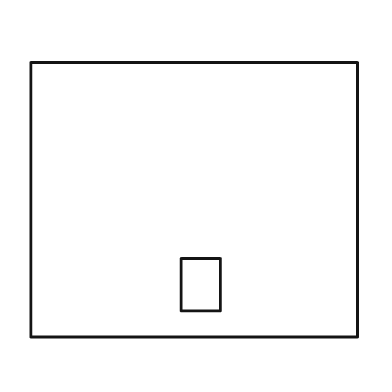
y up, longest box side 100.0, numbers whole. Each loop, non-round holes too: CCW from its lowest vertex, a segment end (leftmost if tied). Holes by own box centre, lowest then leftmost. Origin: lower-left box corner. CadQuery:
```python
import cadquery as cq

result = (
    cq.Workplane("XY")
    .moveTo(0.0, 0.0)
    .lineTo(100.0, 0.0)
    .lineTo(100.0, 84.0)
    .lineTo(0.0, 84.0)
    .close()
    .moveTo(46.0, 8.0)
    .lineTo(58.0, 8.0)
    .lineTo(58.0, 24.0)
    .lineTo(46.0, 24.0)
    .close()
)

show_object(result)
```